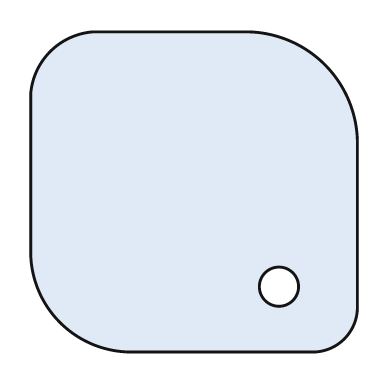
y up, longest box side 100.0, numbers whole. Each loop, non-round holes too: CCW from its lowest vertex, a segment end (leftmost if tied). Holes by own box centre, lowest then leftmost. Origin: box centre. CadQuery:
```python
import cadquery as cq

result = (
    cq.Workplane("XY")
    .moveTo(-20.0, -49.0)
    .lineTo(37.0, -49.0)
    .threePointArc((46.0, -45.0), (50.0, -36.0))
    .lineTo(50.0, 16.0)
    .threePointArc((40.0, 39.0), (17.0, 49.0))
    .lineTo(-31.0, 49.0)
    .threePointArc((-44.0, 43.0), (-50.0, 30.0))
    .lineTo(-50.0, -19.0)
    .threePointArc((-41.0, -40.0), (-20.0, -49.0))
    .close()
    .moveTo(26.0, -29.0)
    .circle(6.0)
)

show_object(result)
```